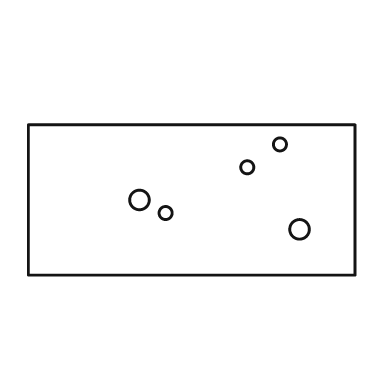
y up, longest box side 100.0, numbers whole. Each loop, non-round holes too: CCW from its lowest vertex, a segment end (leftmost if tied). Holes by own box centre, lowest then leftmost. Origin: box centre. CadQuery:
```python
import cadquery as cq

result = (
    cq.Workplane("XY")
    .moveTo(-50.0, -23.0)
    .lineTo(50.0, -23.0)
    .lineTo(50.0, 23.0)
    .lineTo(-50.0, 23.0)
    .close()
    .moveTo(33.0, -9.0)
    .circle(3.0)
    .moveTo(-8.0, -4.0)
    .circle(2.0)
    .moveTo(-16.0, 0.0)
    .circle(3.0)
    .moveTo(17.0, 10.0)
    .circle(2.0)
    .moveTo(27.0, 17.0)
    .circle(2.0)
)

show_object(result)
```